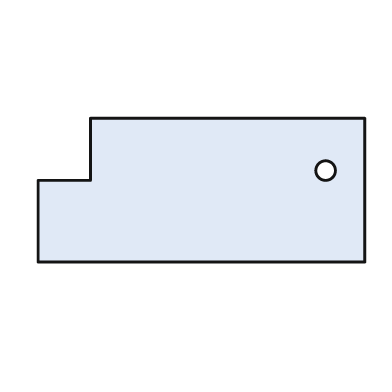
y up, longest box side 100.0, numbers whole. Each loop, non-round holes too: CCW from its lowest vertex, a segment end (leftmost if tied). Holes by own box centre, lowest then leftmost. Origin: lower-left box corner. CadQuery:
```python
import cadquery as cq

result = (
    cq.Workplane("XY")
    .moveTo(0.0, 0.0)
    .lineTo(100.0, 0.0)
    .lineTo(100.0, 44.0)
    .lineTo(16.0, 44.0)
    .lineTo(16.0, 25.0)
    .lineTo(0.0, 25.0)
    .close()
    .moveTo(88.0, 28.0)
    .circle(3.0)
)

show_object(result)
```